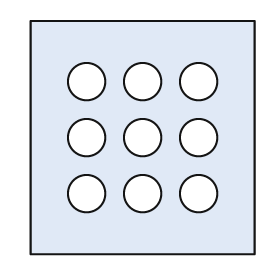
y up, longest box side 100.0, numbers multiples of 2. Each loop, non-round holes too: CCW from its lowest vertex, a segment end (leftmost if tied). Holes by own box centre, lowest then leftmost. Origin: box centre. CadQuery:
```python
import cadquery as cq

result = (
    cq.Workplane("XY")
    .moveTo(-48.0, -50.0)
    .lineTo(48.0, -50.0)
    .lineTo(48.0, 50.0)
    .lineTo(-48.0, 50.0)
    .close()
    .moveTo(-24.0, -24.0)
    .circle(8.0)
    .moveTo(0.0, -24.0)
    .circle(8.0)
    .moveTo(24.0, -24.0)
    .circle(8.0)
    .moveTo(-24.0, 0.0)
    .circle(8.0)
    .moveTo(0.0, 0.0)
    .circle(8.0)
    .moveTo(24.0, 0.0)
    .circle(8.0)
    .moveTo(-24.0, 24.0)
    .circle(8.0)
    .moveTo(0.0, 24.0)
    .circle(8.0)
    .moveTo(24.0, 24.0)
    .circle(8.0)
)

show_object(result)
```